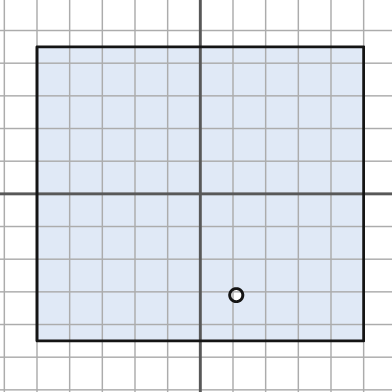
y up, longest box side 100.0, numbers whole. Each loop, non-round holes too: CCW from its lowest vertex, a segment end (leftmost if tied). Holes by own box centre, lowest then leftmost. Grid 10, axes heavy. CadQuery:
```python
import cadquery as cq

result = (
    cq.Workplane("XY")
    .moveTo(-50.0, -45.0)
    .lineTo(50.0, -45.0)
    .lineTo(50.0, 45.0)
    .lineTo(-50.0, 45.0)
    .close()
    .moveTo(11.0, -31.0)
    .circle(2.0)
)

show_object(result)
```